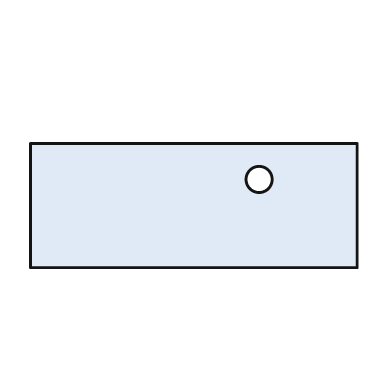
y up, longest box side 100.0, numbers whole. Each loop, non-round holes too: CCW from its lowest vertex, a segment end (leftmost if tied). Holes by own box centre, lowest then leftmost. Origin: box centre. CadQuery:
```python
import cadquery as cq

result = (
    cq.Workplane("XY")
    .moveTo(-50.0, -19.0)
    .lineTo(50.0, -19.0)
    .lineTo(50.0, 19.0)
    .lineTo(-50.0, 19.0)
    .close()
    .moveTo(20.0, 8.0)
    .circle(4.0)
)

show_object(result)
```